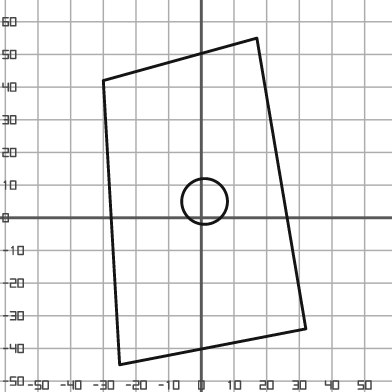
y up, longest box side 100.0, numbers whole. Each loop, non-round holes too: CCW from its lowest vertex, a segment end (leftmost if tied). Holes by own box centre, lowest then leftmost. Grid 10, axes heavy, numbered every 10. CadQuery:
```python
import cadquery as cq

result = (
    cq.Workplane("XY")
    .moveTo(-25.0, -45.0)
    .lineTo(32.0, -34.0)
    .lineTo(17.0, 55.0)
    .lineTo(-30.0, 42.0)
    .close()
    .moveTo(1.0, 5.0)
    .circle(7.0)
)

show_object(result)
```